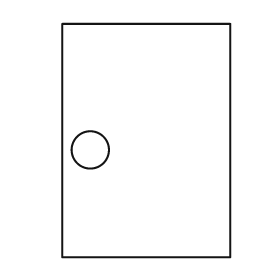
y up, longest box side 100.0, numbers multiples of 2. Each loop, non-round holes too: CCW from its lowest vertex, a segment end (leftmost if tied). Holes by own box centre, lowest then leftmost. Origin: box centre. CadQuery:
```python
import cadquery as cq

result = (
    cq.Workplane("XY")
    .moveTo(-36.0, -50.0)
    .lineTo(36.0, -50.0)
    .lineTo(36.0, 50.0)
    .lineTo(-36.0, 50.0)
    .close()
    .moveTo(-24.0, -4.0)
    .circle(8.0)
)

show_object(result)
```